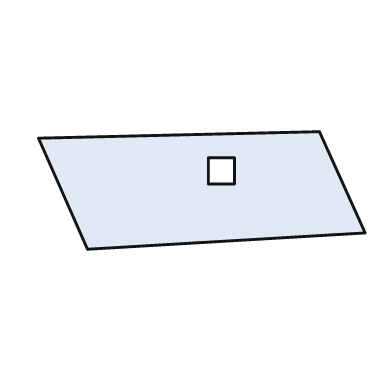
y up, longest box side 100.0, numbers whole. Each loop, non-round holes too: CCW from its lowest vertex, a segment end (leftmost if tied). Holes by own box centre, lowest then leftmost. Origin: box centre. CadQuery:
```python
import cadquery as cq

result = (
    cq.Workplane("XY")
    .moveTo(-35.0, -18.0)
    .lineTo(50.0, -13.0)
    .lineTo(36.0, 18.0)
    .lineTo(-50.0, 16.0)
    .close()
    .moveTo(2.0, 2.0)
    .lineTo(10.0, 2.0)
    .lineTo(10.0, 10.0)
    .lineTo(2.0, 10.0)
    .close()
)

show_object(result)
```